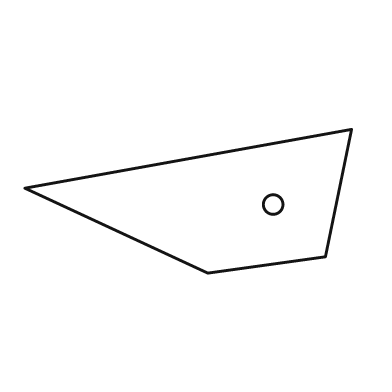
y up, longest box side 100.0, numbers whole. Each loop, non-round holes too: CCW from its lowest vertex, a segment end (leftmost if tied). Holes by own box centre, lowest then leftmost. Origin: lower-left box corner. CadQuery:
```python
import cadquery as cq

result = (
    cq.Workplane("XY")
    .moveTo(56.0, 0.0)
    .lineTo(92.0, 5.0)
    .lineTo(100.0, 44.0)
    .lineTo(0.0, 26.0)
    .close()
    .moveTo(76.0, 21.0)
    .circle(3.0)
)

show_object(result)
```